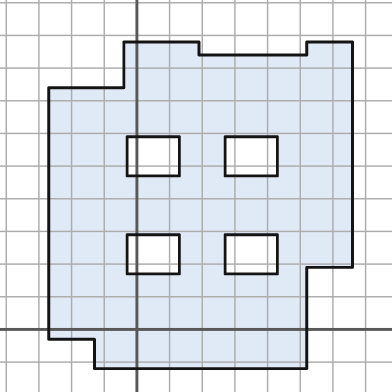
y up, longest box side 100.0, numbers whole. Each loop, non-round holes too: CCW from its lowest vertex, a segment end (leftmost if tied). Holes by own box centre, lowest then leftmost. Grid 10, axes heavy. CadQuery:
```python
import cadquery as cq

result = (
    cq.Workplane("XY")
    .moveTo(-13.0, -12.0)
    .lineTo(52.0, -12.0)
    .lineTo(52.0, 19.0)
    .lineTo(66.0, 19.0)
    .lineTo(66.0, 88.0)
    .lineTo(52.0, 88.0)
    .lineTo(52.0, 84.0)
    .lineTo(19.0, 84.0)
    .lineTo(19.0, 88.0)
    .lineTo(-4.0, 88.0)
    .lineTo(-4.0, 74.0)
    .lineTo(-27.0, 74.0)
    .lineTo(-27.0, -3.0)
    .lineTo(-13.0, -3.0)
    .close()
    .moveTo(-3.0, 17.0)
    .lineTo(13.0, 17.0)
    .lineTo(13.0, 29.0)
    .lineTo(-3.0, 29.0)
    .close()
    .moveTo(27.0, 17.0)
    .lineTo(43.0, 17.0)
    .lineTo(43.0, 29.0)
    .lineTo(27.0, 29.0)
    .close()
    .moveTo(-3.0, 47.0)
    .lineTo(13.0, 47.0)
    .lineTo(13.0, 59.0)
    .lineTo(-3.0, 59.0)
    .close()
    .moveTo(27.0, 47.0)
    .lineTo(43.0, 47.0)
    .lineTo(43.0, 59.0)
    .lineTo(27.0, 59.0)
    .close()
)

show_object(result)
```